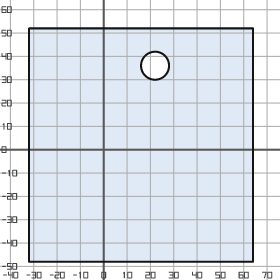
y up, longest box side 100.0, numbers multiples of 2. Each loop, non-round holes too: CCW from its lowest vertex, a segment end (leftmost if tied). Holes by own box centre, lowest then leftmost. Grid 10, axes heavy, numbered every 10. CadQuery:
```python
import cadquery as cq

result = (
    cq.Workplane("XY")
    .moveTo(-32.0, -48.0)
    .lineTo(64.0, -48.0)
    .lineTo(64.0, 52.0)
    .lineTo(-32.0, 52.0)
    .close()
    .moveTo(22.0, 36.0)
    .circle(6.0)
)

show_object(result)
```